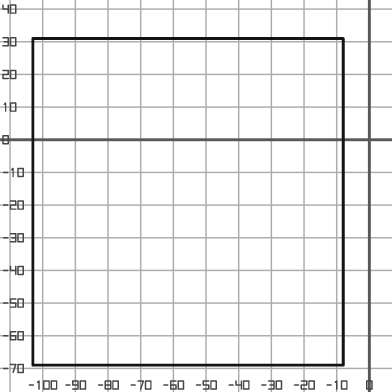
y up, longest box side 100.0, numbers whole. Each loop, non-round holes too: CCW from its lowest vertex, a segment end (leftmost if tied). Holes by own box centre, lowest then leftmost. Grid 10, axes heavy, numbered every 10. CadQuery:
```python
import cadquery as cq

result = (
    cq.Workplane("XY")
    .moveTo(-103.0, -69.0)
    .lineTo(-8.0, -69.0)
    .lineTo(-8.0, 31.0)
    .lineTo(-103.0, 31.0)
    .close()
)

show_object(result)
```